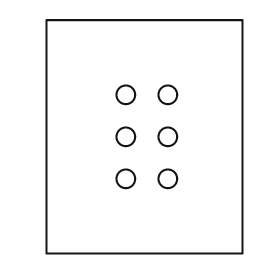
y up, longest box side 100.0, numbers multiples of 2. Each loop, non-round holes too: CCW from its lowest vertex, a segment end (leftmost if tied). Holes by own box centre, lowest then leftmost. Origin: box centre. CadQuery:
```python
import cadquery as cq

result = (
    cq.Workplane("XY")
    .moveTo(-42.0, -50.0)
    .lineTo(42.0, -50.0)
    .lineTo(42.0, 50.0)
    .lineTo(-42.0, 50.0)
    .close()
    .moveTo(-8.0, -18.0)
    .circle(4.0)
    .moveTo(10.0, -18.0)
    .circle(4.0)
    .moveTo(-8.0, 0.0)
    .circle(4.0)
    .moveTo(10.0, 0.0)
    .circle(4.0)
    .moveTo(-8.0, 18.0)
    .circle(4.0)
    .moveTo(10.0, 18.0)
    .circle(4.0)
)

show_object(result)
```